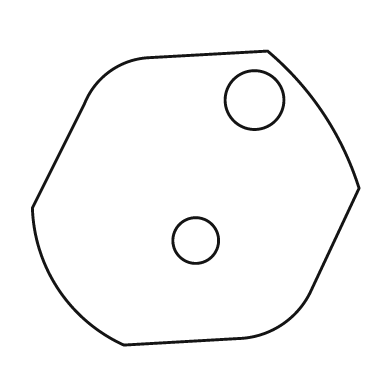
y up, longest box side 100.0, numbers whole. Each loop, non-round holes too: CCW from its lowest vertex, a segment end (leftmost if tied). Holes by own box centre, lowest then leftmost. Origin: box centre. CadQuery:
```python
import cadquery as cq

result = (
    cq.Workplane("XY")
    .moveTo(-22.0, -45.0)
    .lineTo(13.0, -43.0)
    .threePointArc((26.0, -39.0), (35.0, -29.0))
    .lineTo(50.0, 3.0)
    .threePointArc((39.0, 26.0), (22.0, 45.0))
    .lineTo(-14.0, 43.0)
    .threePointArc((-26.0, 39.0), (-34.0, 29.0))
    .lineTo(-50.0, -3.0)
    .threePointArc((-42.0, -28.0), (-22.0, -45.0))
    .close()
    .moveTo(0.0, -13.0)
    .circle(7.0)
    .moveTo(18.0, 30.0)
    .circle(9.0)
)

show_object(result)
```